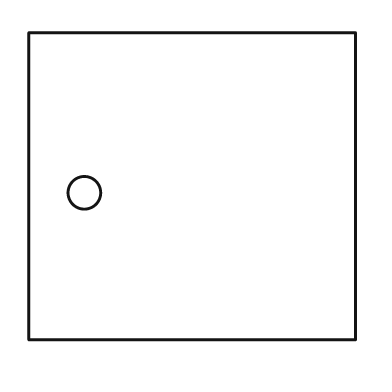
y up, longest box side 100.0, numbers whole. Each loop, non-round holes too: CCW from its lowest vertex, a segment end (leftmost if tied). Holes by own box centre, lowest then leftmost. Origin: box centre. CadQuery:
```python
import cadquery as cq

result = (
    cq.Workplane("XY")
    .moveTo(-50.0, -47.0)
    .lineTo(50.0, -47.0)
    .lineTo(50.0, 47.0)
    .lineTo(-50.0, 47.0)
    .close()
    .moveTo(-33.0, -2.0)
    .circle(5.0)
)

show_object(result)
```